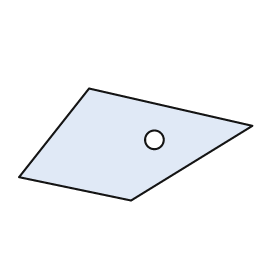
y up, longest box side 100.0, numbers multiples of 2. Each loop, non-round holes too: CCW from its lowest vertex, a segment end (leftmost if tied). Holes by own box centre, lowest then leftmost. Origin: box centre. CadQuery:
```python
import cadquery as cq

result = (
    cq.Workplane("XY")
    .moveTo(-2.0, -24.0)
    .lineTo(50.0, 8.0)
    .lineTo(-20.0, 24.0)
    .lineTo(-50.0, -14.0)
    .close()
    .moveTo(8.0, 2.0)
    .circle(4.0)
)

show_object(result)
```